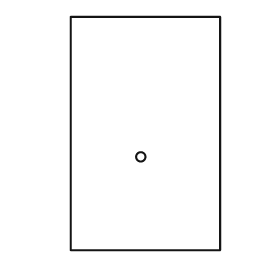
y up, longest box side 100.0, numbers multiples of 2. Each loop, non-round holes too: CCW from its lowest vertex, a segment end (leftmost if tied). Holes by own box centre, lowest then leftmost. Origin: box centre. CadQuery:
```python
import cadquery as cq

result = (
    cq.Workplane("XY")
    .moveTo(-32.0, -50.0)
    .lineTo(32.0, -50.0)
    .lineTo(32.0, 50.0)
    .lineTo(-32.0, 50.0)
    .close()
    .moveTo(-2.0, -10.0)
    .circle(2.0)
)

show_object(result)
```